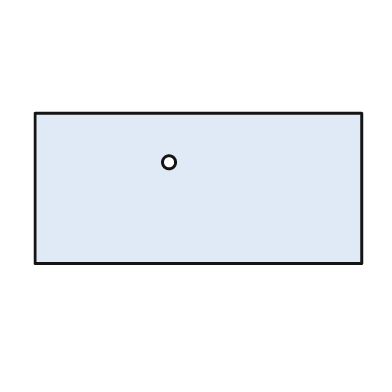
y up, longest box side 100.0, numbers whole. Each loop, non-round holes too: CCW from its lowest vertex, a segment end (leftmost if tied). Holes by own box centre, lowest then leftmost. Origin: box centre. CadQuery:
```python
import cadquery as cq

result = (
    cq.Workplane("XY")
    .moveTo(-50.0, -23.0)
    .lineTo(50.0, -23.0)
    .lineTo(50.0, 23.0)
    .lineTo(-50.0, 23.0)
    .close()
    .moveTo(-9.0, 8.0)
    .circle(2.0)
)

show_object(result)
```